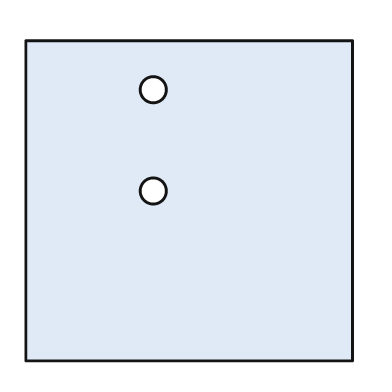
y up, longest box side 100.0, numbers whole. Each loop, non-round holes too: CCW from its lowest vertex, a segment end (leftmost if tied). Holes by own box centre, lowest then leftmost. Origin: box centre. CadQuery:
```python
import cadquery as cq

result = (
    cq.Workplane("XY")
    .moveTo(-50.0, -49.0)
    .lineTo(50.0, -49.0)
    .lineTo(50.0, 49.0)
    .lineTo(-50.0, 49.0)
    .close()
    .moveTo(-11.0, 3.0)
    .circle(4.0)
    .moveTo(-11.0, 34.0)
    .circle(4.0)
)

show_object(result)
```